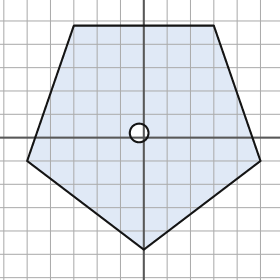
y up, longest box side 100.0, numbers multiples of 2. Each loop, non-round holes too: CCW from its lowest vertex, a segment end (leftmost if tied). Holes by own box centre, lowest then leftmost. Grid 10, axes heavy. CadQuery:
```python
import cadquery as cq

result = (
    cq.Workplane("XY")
    .moveTo(0.0, -48.0)
    .lineTo(50.0, -10.0)
    .lineTo(30.0, 48.0)
    .lineTo(-30.0, 48.0)
    .lineTo(-50.0, -10.0)
    .close()
    .moveTo(-2.0, 2.0)
    .circle(4.0)
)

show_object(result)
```